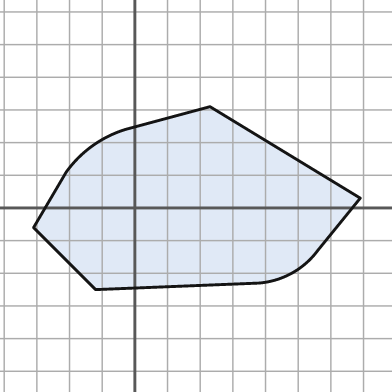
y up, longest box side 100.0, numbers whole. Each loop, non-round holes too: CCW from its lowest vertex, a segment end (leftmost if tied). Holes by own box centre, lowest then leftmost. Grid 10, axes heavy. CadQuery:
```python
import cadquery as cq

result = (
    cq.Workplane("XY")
    .moveTo(-12.0, -25.0)
    .lineTo(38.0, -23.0)
    .threePointArc((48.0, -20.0), (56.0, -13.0))
    .lineTo(69.0, 3.0)
    .lineTo(23.0, 31.0)
    .lineTo(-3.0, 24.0)
    .threePointArc((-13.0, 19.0), (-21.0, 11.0))
    .lineTo(-31.0, -6.0)
    .close()
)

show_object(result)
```